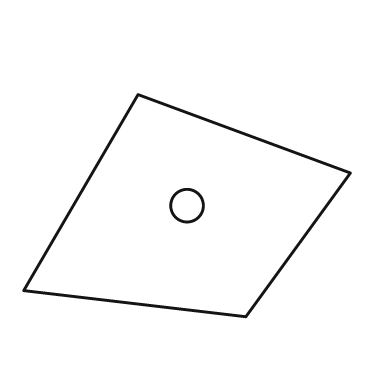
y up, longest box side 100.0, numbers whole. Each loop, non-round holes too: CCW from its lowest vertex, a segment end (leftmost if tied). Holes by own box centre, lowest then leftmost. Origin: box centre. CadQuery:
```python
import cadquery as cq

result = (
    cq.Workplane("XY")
    .moveTo(18.0, -34.0)
    .lineTo(50.0, 10.0)
    .lineTo(-15.0, 34.0)
    .lineTo(-50.0, -26.0)
    .close()
    .moveTo(0.0, 0.0)
    .circle(5.0)
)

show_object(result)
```